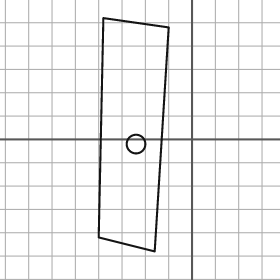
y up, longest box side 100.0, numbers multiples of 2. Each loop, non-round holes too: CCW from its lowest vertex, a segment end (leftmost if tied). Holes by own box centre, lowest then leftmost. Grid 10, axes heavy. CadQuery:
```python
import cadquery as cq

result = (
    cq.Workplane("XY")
    .moveTo(-16.0, -48.0)
    .lineTo(-10.0, 48.0)
    .lineTo(-38.0, 52.0)
    .lineTo(-40.0, -42.0)
    .close()
    .moveTo(-24.0, -2.0)
    .circle(4.0)
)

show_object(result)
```